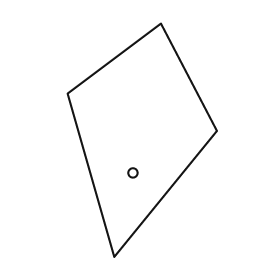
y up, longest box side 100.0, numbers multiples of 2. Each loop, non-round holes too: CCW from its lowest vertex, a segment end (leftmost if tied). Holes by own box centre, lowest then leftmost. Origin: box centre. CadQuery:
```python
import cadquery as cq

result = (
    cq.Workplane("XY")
    .moveTo(-12.0, -50.0)
    .lineTo(32.0, 4.0)
    .lineTo(8.0, 50.0)
    .lineTo(-32.0, 20.0)
    .close()
    .moveTo(-4.0, -14.0)
    .circle(2.0)
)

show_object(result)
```